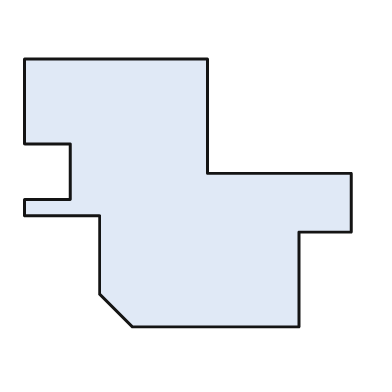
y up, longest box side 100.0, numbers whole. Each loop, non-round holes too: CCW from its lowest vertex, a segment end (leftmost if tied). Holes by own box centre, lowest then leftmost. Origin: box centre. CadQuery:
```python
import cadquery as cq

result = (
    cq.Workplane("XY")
    .moveTo(-17.0, -41.0)
    .lineTo(34.0, -41.0)
    .lineTo(34.0, -12.0)
    .lineTo(50.0, -12.0)
    .lineTo(50.0, 6.0)
    .lineTo(6.0, 6.0)
    .lineTo(6.0, 41.0)
    .lineTo(-50.0, 41.0)
    .lineTo(-50.0, 15.0)
    .lineTo(-36.0, 15.0)
    .lineTo(-36.0, -2.0)
    .lineTo(-50.0, -2.0)
    .lineTo(-50.0, -7.0)
    .lineTo(-27.0, -7.0)
    .lineTo(-27.0, -31.0)
    .close()
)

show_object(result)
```